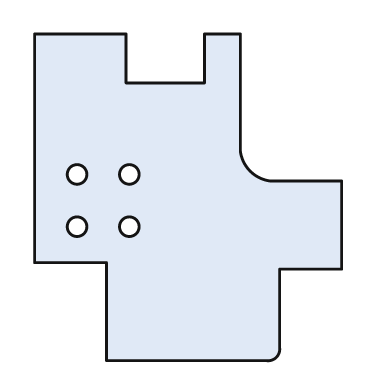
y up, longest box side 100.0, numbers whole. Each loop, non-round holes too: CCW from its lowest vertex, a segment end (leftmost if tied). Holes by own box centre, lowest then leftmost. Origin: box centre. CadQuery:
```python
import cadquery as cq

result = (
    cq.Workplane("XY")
    .moveTo(-25.0, -50.0)
    .lineTo(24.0, -50.0)
    .threePointArc((27.0, -49.0), (28.0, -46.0))
    .lineTo(28.0, -22.0)
    .lineTo(47.0, -22.0)
    .lineTo(47.0, 5.0)
    .lineTo(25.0, 5.0)
    .threePointArc((19.0, 8.0), (16.0, 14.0))
    .lineTo(16.0, 50.0)
    .lineTo(5.0, 50.0)
    .lineTo(5.0, 35.0)
    .lineTo(-19.0, 35.0)
    .lineTo(-19.0, 50.0)
    .lineTo(-47.0, 50.0)
    .lineTo(-47.0, -20.0)
    .lineTo(-25.0, -20.0)
    .close()
    .moveTo(-34.0, -9.0)
    .circle(3.0)
    .moveTo(-18.0, -9.0)
    .circle(3.0)
    .moveTo(-34.0, 7.0)
    .circle(3.0)
    .moveTo(-18.0, 7.0)
    .circle(3.0)
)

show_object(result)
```